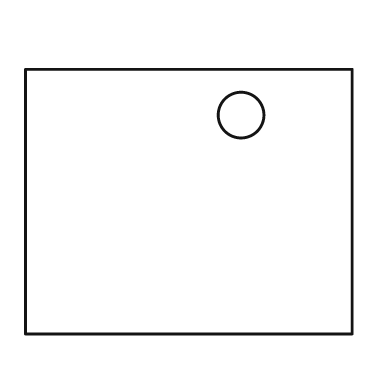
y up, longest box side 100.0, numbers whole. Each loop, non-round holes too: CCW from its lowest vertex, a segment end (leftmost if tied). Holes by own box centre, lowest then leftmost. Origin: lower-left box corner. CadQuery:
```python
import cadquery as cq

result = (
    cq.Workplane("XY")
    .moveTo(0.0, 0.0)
    .lineTo(100.0, 0.0)
    .lineTo(100.0, 81.0)
    .lineTo(0.0, 81.0)
    .close()
    .moveTo(66.0, 67.0)
    .circle(7.0)
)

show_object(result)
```